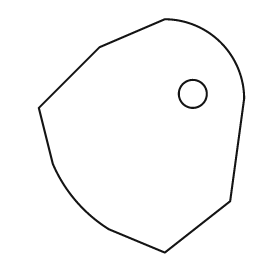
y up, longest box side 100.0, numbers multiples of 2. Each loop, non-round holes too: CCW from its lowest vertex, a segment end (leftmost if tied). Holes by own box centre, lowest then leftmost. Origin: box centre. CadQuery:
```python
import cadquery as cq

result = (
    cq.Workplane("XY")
    .moveTo(10.0, -50.0)
    .lineTo(38.0, -28.0)
    .lineTo(44.0, 16.0)
    .threePointArc((34.0, 40.0), (10.0, 50.0))
    .lineTo(-18.0, 38.0)
    .lineTo(-44.0, 12.0)
    .lineTo(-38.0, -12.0)
    .threePointArc((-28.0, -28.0), (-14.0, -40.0))
    .close()
    .moveTo(22.0, 18.0)
    .circle(6.0)
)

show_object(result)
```